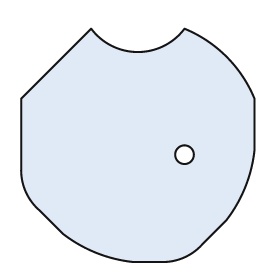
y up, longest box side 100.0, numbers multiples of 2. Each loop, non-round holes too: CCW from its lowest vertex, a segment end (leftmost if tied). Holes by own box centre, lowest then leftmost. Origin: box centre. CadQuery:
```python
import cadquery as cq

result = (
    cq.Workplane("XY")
    .moveTo(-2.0, -50.0)
    .lineTo(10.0, -50.0)
    .threePointArc((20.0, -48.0), (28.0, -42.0))
    .lineTo(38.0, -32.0)
    .threePointArc((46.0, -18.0), (50.0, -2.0))
    .lineTo(50.0, 20.0)
    .threePointArc((38.0, 38.0), (20.0, 50.0))
    .threePointArc((0.0, 40.0), (-20.0, 50.0))
    .lineTo(-50.0, 20.0)
    .lineTo(-50.0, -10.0)
    .threePointArc((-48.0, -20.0), (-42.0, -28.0))
    .lineTo(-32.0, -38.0)
    .threePointArc((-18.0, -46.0), (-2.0, -50.0))
    .close()
    .moveTo(20.0, -4.0)
    .circle(4.0)
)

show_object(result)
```